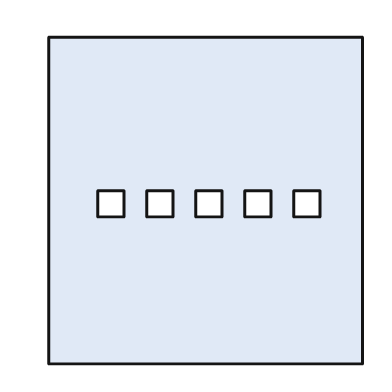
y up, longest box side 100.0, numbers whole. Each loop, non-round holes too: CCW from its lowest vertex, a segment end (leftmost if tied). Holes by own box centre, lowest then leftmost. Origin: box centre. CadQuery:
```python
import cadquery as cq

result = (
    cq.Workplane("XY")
    .moveTo(-48.0, -50.0)
    .lineTo(48.0, -50.0)
    .lineTo(48.0, 50.0)
    .lineTo(-48.0, 50.0)
    .close()
    .moveTo(-33.0, -5.0)
    .lineTo(-25.0, -5.0)
    .lineTo(-25.0, 3.0)
    .lineTo(-33.0, 3.0)
    .close()
    .moveTo(-18.0, -5.0)
    .lineTo(-10.0, -5.0)
    .lineTo(-10.0, 3.0)
    .lineTo(-18.0, 3.0)
    .close()
    .moveTo(-3.0, -5.0)
    .lineTo(5.0, -5.0)
    .lineTo(5.0, 3.0)
    .lineTo(-3.0, 3.0)
    .close()
    .moveTo(12.0, -5.0)
    .lineTo(20.0, -5.0)
    .lineTo(20.0, 3.0)
    .lineTo(12.0, 3.0)
    .close()
    .moveTo(27.0, -5.0)
    .lineTo(35.0, -5.0)
    .lineTo(35.0, 3.0)
    .lineTo(27.0, 3.0)
    .close()
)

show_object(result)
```